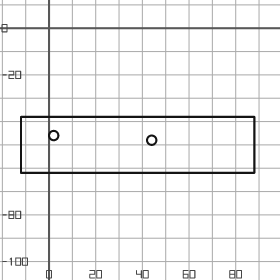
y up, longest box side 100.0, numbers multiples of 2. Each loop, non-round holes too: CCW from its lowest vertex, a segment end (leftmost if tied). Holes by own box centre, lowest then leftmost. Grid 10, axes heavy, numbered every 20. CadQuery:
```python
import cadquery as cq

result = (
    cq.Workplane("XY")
    .moveTo(-12.0, -62.0)
    .lineTo(88.0, -62.0)
    .lineTo(88.0, -38.0)
    .lineTo(-12.0, -38.0)
    .close()
    .moveTo(44.0, -48.0)
    .circle(2.0)
    .moveTo(2.0, -46.0)
    .circle(2.0)
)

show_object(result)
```